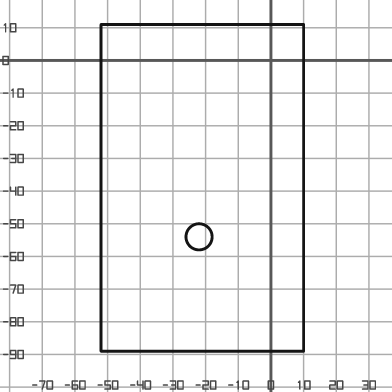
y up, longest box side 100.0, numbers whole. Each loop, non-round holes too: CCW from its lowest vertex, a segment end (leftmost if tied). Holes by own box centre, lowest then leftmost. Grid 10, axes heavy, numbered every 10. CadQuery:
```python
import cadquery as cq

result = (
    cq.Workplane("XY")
    .moveTo(-52.0, -89.0)
    .lineTo(10.0, -89.0)
    .lineTo(10.0, 11.0)
    .lineTo(-52.0, 11.0)
    .close()
    .moveTo(-22.0, -54.0)
    .circle(4.0)
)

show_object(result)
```